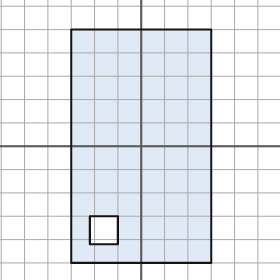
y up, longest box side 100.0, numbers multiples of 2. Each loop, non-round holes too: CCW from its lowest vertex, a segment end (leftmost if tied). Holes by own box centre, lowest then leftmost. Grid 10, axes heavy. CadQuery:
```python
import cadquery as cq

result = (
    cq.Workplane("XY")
    .moveTo(-30.0, -50.0)
    .lineTo(30.0, -50.0)
    .lineTo(30.0, 50.0)
    .lineTo(-30.0, 50.0)
    .close()
    .moveTo(-22.0, -42.0)
    .lineTo(-10.0, -42.0)
    .lineTo(-10.0, -30.0)
    .lineTo(-22.0, -30.0)
    .close()
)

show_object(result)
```